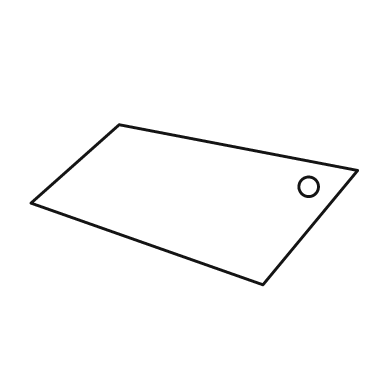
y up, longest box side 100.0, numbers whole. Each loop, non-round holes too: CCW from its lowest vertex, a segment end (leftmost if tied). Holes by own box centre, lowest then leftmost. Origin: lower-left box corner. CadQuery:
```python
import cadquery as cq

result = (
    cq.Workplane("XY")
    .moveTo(71.0, 0.0)
    .lineTo(100.0, 35.0)
    .lineTo(27.0, 49.0)
    .lineTo(0.0, 25.0)
    .close()
    .moveTo(85.0, 30.0)
    .circle(3.0)
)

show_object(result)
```